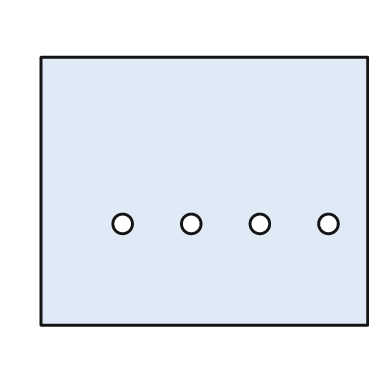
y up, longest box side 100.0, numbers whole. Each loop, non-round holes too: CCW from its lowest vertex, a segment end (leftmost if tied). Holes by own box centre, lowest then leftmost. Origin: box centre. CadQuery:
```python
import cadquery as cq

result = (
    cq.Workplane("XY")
    .moveTo(-50.0, -41.0)
    .lineTo(50.0, -41.0)
    .lineTo(50.0, 41.0)
    .lineTo(-50.0, 41.0)
    .close()
    .moveTo(-25.0, -10.0)
    .circle(3.0)
    .moveTo(-4.0, -10.0)
    .circle(3.0)
    .moveTo(17.0, -10.0)
    .circle(3.0)
    .moveTo(38.0, -10.0)
    .circle(3.0)
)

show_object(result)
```